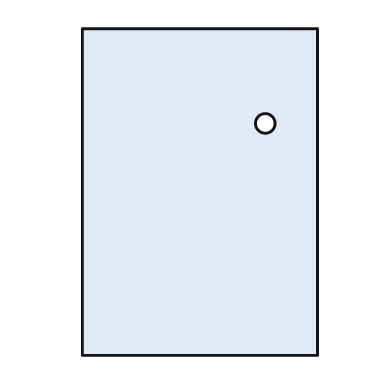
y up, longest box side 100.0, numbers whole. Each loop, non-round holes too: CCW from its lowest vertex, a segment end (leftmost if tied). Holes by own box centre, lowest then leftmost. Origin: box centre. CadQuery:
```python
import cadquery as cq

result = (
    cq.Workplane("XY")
    .moveTo(-36.0, -50.0)
    .lineTo(36.0, -50.0)
    .lineTo(36.0, 50.0)
    .lineTo(-36.0, 50.0)
    .close()
    .moveTo(20.0, 21.0)
    .circle(3.0)
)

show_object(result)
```